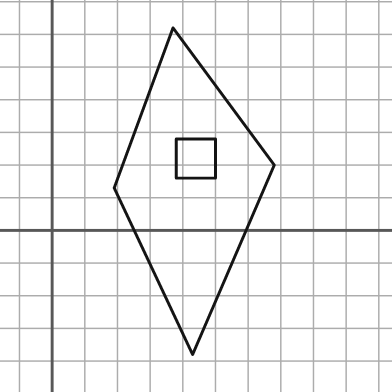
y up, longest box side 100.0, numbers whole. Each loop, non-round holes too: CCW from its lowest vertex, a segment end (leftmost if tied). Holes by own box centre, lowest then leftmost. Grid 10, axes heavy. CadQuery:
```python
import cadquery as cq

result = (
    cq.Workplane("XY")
    .moveTo(43.0, -38.0)
    .lineTo(68.0, 20.0)
    .lineTo(37.0, 62.0)
    .lineTo(19.0, 13.0)
    .close()
    .moveTo(38.0, 16.0)
    .lineTo(50.0, 16.0)
    .lineTo(50.0, 28.0)
    .lineTo(38.0, 28.0)
    .close()
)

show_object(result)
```